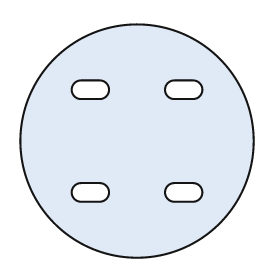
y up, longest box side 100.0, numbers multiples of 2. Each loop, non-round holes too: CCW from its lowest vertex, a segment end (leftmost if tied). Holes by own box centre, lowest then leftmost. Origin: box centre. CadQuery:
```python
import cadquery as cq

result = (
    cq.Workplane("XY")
    .moveTo(0.0, 0.0)
    .circle(50.0)
    .moveTo(-24.0, -26.0)
    .lineTo(-16.0, -26.0)
    .threePointArc((-12.0, -22.0), (-16.0, -18.0))
    .lineTo(-24.0, -18.0)
    .threePointArc((-28.0, -22.0), (-24.0, -26.0))
    .close()
    .moveTo(16.0, -26.0)
    .lineTo(24.0, -26.0)
    .threePointArc((28.0, -22.0), (24.0, -18.0))
    .lineTo(16.0, -18.0)
    .threePointArc((12.0, -22.0), (16.0, -26.0))
    .close()
    .moveTo(-24.0, 18.0)
    .lineTo(-16.0, 18.0)
    .threePointArc((-12.0, 22.0), (-16.0, 26.0))
    .lineTo(-24.0, 26.0)
    .threePointArc((-28.0, 22.0), (-24.0, 18.0))
    .close()
    .moveTo(16.0, 18.0)
    .lineTo(24.0, 18.0)
    .threePointArc((28.0, 22.0), (24.0, 26.0))
    .lineTo(16.0, 26.0)
    .threePointArc((12.0, 22.0), (16.0, 18.0))
    .close()
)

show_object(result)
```